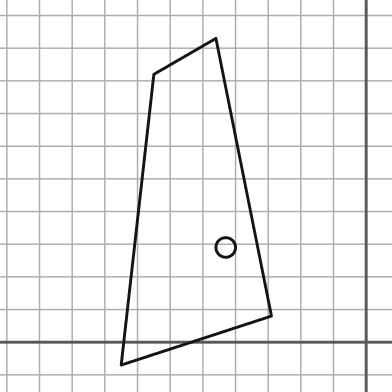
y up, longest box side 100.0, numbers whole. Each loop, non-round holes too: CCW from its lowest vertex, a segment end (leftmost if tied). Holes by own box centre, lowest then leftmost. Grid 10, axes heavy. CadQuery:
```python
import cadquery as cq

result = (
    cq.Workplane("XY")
    .moveTo(-75.0, -7.0)
    .lineTo(-29.0, 8.0)
    .lineTo(-46.0, 93.0)
    .lineTo(-65.0, 82.0)
    .close()
    .moveTo(-43.0, 29.0)
    .circle(3.0)
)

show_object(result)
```